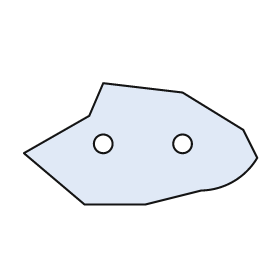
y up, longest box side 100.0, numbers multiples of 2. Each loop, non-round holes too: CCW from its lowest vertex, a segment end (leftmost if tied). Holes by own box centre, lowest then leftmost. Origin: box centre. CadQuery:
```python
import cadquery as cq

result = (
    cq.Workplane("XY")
    .moveTo(-24.0, -26.0)
    .lineTo(2.0, -26.0)
    .lineTo(26.0, -20.0)
    .threePointArc((40.0, -16.0), (50.0, -6.0))
    .lineTo(44.0, 6.0)
    .lineTo(18.0, 22.0)
    .lineTo(-16.0, 26.0)
    .lineTo(-22.0, 12.0)
    .lineTo(-50.0, -4.0)
    .close()
    .moveTo(-16.0, 0.0)
    .circle(4.0)
    .moveTo(18.0, 0.0)
    .circle(4.0)
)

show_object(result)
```